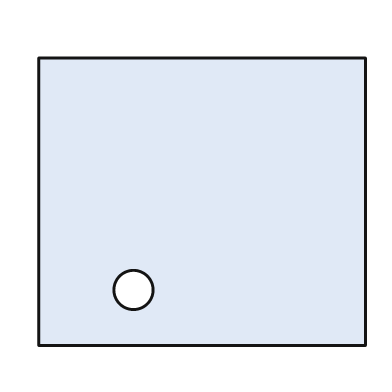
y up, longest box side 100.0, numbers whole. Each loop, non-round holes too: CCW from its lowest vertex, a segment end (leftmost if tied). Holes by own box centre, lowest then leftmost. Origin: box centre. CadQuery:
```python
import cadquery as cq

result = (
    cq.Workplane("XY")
    .moveTo(-50.0, -44.0)
    .lineTo(50.0, -44.0)
    .lineTo(50.0, 44.0)
    .lineTo(-50.0, 44.0)
    .close()
    .moveTo(-21.0, -27.0)
    .circle(6.0)
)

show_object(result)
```